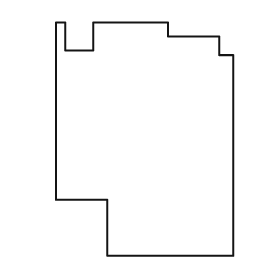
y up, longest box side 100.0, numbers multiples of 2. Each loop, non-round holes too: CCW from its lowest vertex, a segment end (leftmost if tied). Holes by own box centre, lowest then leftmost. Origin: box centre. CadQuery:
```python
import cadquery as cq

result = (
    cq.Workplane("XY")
    .moveTo(-16.0, -50.0)
    .lineTo(38.0, -50.0)
    .lineTo(38.0, 36.0)
    .lineTo(32.0, 36.0)
    .lineTo(32.0, 44.0)
    .lineTo(10.0, 44.0)
    .lineTo(10.0, 50.0)
    .lineTo(-22.0, 50.0)
    .lineTo(-22.0, 38.0)
    .lineTo(-34.0, 38.0)
    .lineTo(-34.0, 50.0)
    .lineTo(-38.0, 50.0)
    .lineTo(-38.0, -26.0)
    .lineTo(-16.0, -26.0)
    .close()
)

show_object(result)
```